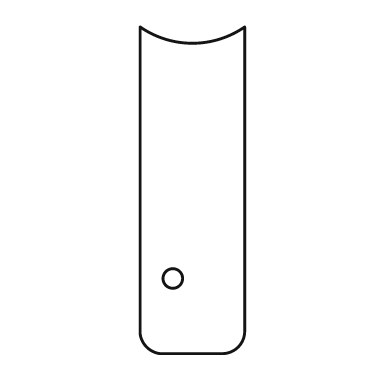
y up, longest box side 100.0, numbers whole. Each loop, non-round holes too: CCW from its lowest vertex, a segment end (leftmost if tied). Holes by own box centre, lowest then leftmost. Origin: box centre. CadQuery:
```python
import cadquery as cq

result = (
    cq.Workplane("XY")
    .moveTo(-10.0, -50.0)
    .lineTo(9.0, -50.0)
    .threePointArc((14.0, -48.0), (16.0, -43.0))
    .lineTo(16.0, 50.0)
    .threePointArc((0.0, 45.0), (-16.0, 50.0))
    .lineTo(-16.0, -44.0)
    .threePointArc((-14.0, -48.0), (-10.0, -50.0))
    .close()
    .moveTo(-6.0, -27.0)
    .circle(3.0)
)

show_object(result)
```